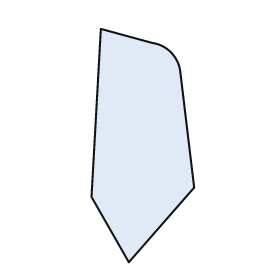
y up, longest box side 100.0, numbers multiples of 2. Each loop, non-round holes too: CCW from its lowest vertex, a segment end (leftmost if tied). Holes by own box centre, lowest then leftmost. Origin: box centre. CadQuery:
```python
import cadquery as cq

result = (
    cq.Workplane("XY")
    .moveTo(-6.0, -50.0)
    .lineTo(22.0, -18.0)
    .lineTo(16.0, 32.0)
    .threePointArc((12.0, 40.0), (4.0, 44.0))
    .lineTo(-18.0, 50.0)
    .lineTo(-22.0, -22.0)
    .close()
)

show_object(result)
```